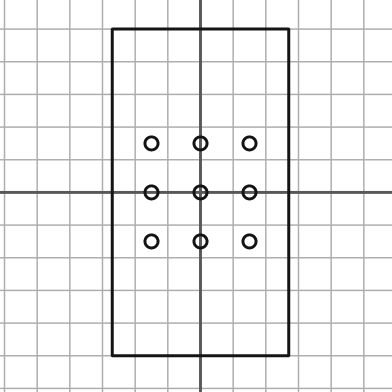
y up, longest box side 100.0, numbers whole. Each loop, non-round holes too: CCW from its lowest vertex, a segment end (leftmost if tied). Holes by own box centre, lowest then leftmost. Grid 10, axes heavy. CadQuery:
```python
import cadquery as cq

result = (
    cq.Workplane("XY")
    .moveTo(-27.0, -50.0)
    .lineTo(27.0, -50.0)
    .lineTo(27.0, 50.0)
    .lineTo(-27.0, 50.0)
    .close()
    .moveTo(-15.0, -15.0)
    .circle(2.0)
    .moveTo(0.0, -15.0)
    .circle(2.0)
    .moveTo(15.0, -15.0)
    .circle(2.0)
    .moveTo(-15.0, 0.0)
    .circle(2.0)
    .moveTo(0.0, 0.0)
    .circle(2.0)
    .moveTo(15.0, 0.0)
    .circle(2.0)
    .moveTo(-15.0, 15.0)
    .circle(2.0)
    .moveTo(0.0, 15.0)
    .circle(2.0)
    .moveTo(15.0, 15.0)
    .circle(2.0)
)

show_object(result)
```